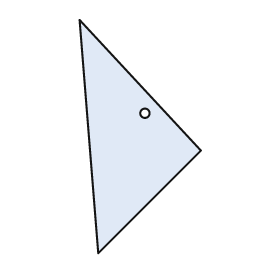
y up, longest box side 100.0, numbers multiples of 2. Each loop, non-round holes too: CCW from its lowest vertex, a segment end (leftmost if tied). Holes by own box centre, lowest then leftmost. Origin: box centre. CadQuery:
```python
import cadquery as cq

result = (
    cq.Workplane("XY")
    .moveTo(-18.0, -50.0)
    .lineTo(26.0, -6.0)
    .lineTo(-26.0, 50.0)
    .close()
    .moveTo(2.0, 10.0)
    .circle(2.0)
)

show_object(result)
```